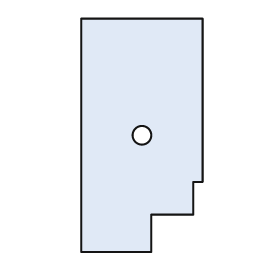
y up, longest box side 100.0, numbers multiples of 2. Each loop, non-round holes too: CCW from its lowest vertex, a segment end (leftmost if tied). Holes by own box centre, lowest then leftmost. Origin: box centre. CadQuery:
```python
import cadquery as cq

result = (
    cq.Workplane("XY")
    .moveTo(-26.0, -50.0)
    .lineTo(4.0, -50.0)
    .lineTo(4.0, -34.0)
    .lineTo(22.0, -34.0)
    .lineTo(22.0, -20.0)
    .lineTo(26.0, -20.0)
    .lineTo(26.0, 50.0)
    .lineTo(-26.0, 50.0)
    .close()
    .moveTo(0.0, 0.0)
    .circle(4.0)
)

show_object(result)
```